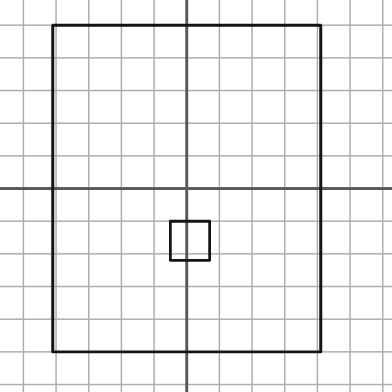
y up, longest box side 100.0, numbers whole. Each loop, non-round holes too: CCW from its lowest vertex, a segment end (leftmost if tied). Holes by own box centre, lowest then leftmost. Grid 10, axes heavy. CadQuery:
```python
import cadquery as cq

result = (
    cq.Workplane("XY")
    .moveTo(-41.0, -50.0)
    .lineTo(41.0, -50.0)
    .lineTo(41.0, 50.0)
    .lineTo(-41.0, 50.0)
    .close()
    .moveTo(-5.0, -22.0)
    .lineTo(7.0, -22.0)
    .lineTo(7.0, -10.0)
    .lineTo(-5.0, -10.0)
    .close()
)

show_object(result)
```